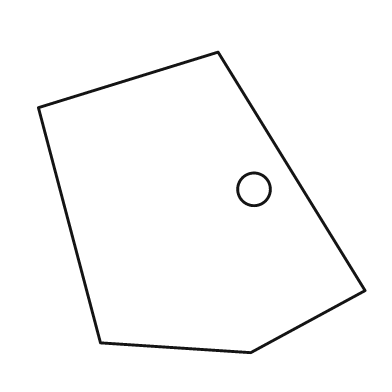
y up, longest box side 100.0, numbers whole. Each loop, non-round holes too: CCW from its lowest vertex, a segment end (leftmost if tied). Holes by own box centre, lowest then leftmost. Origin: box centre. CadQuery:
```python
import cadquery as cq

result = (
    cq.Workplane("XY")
    .moveTo(15.0, -46.0)
    .lineTo(50.0, -27.0)
    .lineTo(5.0, 46.0)
    .lineTo(-50.0, 29.0)
    .lineTo(-31.0, -43.0)
    .close()
    .moveTo(16.0, 4.0)
    .circle(5.0)
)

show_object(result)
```